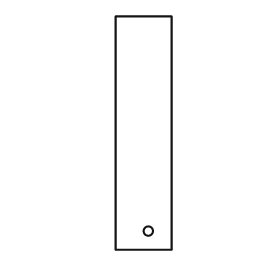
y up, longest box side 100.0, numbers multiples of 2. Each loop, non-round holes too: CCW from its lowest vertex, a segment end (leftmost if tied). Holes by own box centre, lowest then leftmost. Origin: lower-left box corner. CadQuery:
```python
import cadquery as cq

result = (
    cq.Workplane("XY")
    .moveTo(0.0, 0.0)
    .lineTo(24.0, 0.0)
    .lineTo(24.0, 100.0)
    .lineTo(0.0, 100.0)
    .close()
    .moveTo(14.0, 8.0)
    .circle(2.0)
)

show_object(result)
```